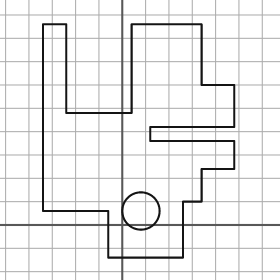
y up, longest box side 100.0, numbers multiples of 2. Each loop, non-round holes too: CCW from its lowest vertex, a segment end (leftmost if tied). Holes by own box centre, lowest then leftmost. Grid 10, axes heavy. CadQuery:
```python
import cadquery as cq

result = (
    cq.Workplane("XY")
    .moveTo(-6.0, -14.0)
    .lineTo(26.0, -14.0)
    .lineTo(26.0, 10.0)
    .lineTo(34.0, 10.0)
    .lineTo(34.0, 24.0)
    .lineTo(48.0, 24.0)
    .lineTo(48.0, 36.0)
    .lineTo(12.0, 36.0)
    .lineTo(12.0, 42.0)
    .lineTo(48.0, 42.0)
    .lineTo(48.0, 60.0)
    .lineTo(34.0, 60.0)
    .lineTo(34.0, 86.0)
    .lineTo(4.0, 86.0)
    .lineTo(4.0, 48.0)
    .lineTo(-24.0, 48.0)
    .lineTo(-24.0, 86.0)
    .lineTo(-34.0, 86.0)
    .lineTo(-34.0, 6.0)
    .lineTo(-6.0, 6.0)
    .close()
    .moveTo(8.0, 6.0)
    .circle(8.0)
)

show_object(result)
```